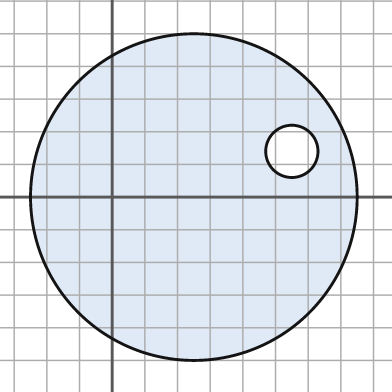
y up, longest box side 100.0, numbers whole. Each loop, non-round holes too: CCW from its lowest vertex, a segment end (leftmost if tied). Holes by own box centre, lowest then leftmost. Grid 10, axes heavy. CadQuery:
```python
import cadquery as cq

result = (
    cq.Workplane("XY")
    .moveTo(25.0, 0.0)
    .circle(50.0)
    .moveTo(55.0, 14.0)
    .circle(8.0)
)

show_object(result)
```